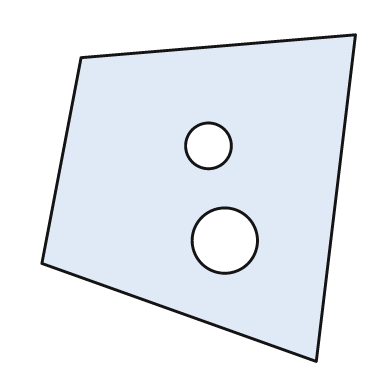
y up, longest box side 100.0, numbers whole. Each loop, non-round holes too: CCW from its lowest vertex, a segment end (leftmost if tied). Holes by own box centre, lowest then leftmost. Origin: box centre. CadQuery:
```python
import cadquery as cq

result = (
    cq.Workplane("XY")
    .moveTo(36.0, -50.0)
    .lineTo(48.0, 50.0)
    .lineTo(-36.0, 43.0)
    .lineTo(-48.0, -20.0)
    .close()
    .moveTo(8.0, -13.0)
    .circle(10.0)
    .moveTo(3.0, 16.0)
    .circle(7.0)
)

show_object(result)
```